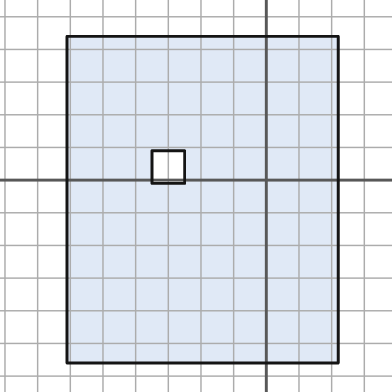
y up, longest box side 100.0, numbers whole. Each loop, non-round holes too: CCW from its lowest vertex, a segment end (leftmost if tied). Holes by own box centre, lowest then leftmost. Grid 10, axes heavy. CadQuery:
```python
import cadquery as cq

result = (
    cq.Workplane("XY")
    .moveTo(-61.0, -56.0)
    .lineTo(22.0, -56.0)
    .lineTo(22.0, 44.0)
    .lineTo(-61.0, 44.0)
    .close()
    .moveTo(-35.0, -1.0)
    .lineTo(-25.0, -1.0)
    .lineTo(-25.0, 9.0)
    .lineTo(-35.0, 9.0)
    .close()
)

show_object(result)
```